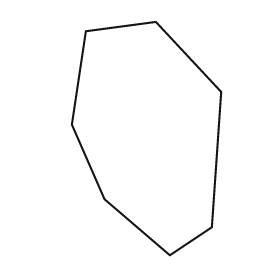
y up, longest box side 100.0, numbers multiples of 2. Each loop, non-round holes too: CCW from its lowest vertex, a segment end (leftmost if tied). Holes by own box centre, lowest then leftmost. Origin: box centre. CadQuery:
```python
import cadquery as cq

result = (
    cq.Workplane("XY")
    .moveTo(10.0, -50.0)
    .lineTo(28.0, -38.0)
    .lineTo(32.0, 20.0)
    .lineTo(4.0, 50.0)
    .lineTo(-26.0, 46.0)
    .lineTo(-32.0, 6.0)
    .lineTo(-18.0, -26.0)
    .close()
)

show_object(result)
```